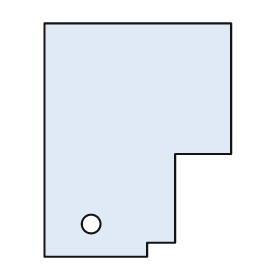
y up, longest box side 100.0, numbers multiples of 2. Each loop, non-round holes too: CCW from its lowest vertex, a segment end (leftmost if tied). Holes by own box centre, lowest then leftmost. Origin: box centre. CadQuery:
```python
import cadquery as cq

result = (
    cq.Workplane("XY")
    .moveTo(-40.0, -50.0)
    .lineTo(4.0, -50.0)
    .lineTo(4.0, -44.0)
    .lineTo(16.0, -44.0)
    .lineTo(16.0, -6.0)
    .lineTo(40.0, -6.0)
    .lineTo(40.0, 50.0)
    .lineTo(-40.0, 50.0)
    .close()
    .moveTo(-20.0, -36.0)
    .circle(4.0)
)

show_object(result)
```